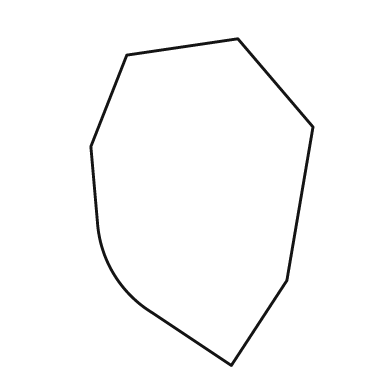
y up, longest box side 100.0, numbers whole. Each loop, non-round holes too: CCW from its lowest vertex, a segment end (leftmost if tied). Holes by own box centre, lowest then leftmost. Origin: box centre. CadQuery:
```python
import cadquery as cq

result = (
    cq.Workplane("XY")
    .moveTo(9.0, -50.0)
    .lineTo(26.0, -24.0)
    .lineTo(34.0, 23.0)
    .lineTo(11.0, 50.0)
    .lineTo(-23.0, 45.0)
    .lineTo(-34.0, 17.0)
    .lineTo(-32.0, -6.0)
    .threePointArc((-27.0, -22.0), (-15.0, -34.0))
    .close()
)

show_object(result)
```